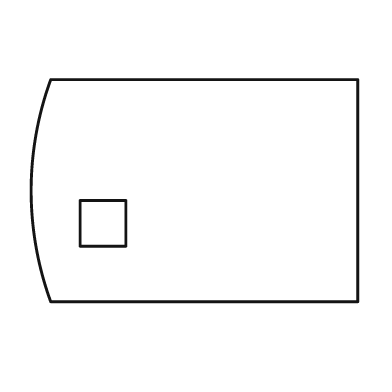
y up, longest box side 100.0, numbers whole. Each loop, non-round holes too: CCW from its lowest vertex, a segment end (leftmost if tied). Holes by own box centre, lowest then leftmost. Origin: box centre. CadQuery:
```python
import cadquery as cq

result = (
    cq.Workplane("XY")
    .moveTo(-44.0, -34.0)
    .lineTo(50.0, -34.0)
    .lineTo(50.0, 34.0)
    .lineTo(-44.0, 34.0)
    .threePointArc((-50.0, 0.0), (-44.0, -34.0))
    .close()
    .moveTo(-35.0, -17.0)
    .lineTo(-21.0, -17.0)
    .lineTo(-21.0, -3.0)
    .lineTo(-35.0, -3.0)
    .close()
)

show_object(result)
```